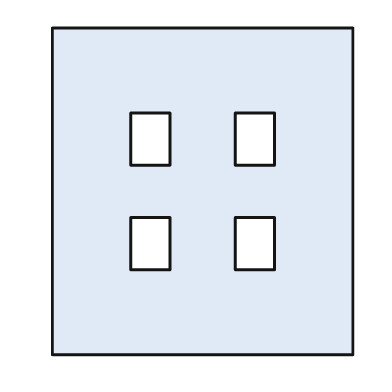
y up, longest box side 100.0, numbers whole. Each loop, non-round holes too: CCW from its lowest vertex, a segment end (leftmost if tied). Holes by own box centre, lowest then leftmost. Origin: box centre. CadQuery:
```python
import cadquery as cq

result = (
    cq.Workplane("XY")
    .moveTo(-46.0, -50.0)
    .lineTo(46.0, -50.0)
    .lineTo(46.0, 50.0)
    .lineTo(-46.0, 50.0)
    .close()
    .moveTo(-22.0, -24.0)
    .lineTo(-10.0, -24.0)
    .lineTo(-10.0, -8.0)
    .lineTo(-22.0, -8.0)
    .close()
    .moveTo(10.0, -24.0)
    .lineTo(22.0, -24.0)
    .lineTo(22.0, -8.0)
    .lineTo(10.0, -8.0)
    .close()
    .moveTo(-22.0, 8.0)
    .lineTo(-10.0, 8.0)
    .lineTo(-10.0, 24.0)
    .lineTo(-22.0, 24.0)
    .close()
    .moveTo(10.0, 8.0)
    .lineTo(22.0, 8.0)
    .lineTo(22.0, 24.0)
    .lineTo(10.0, 24.0)
    .close()
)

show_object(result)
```